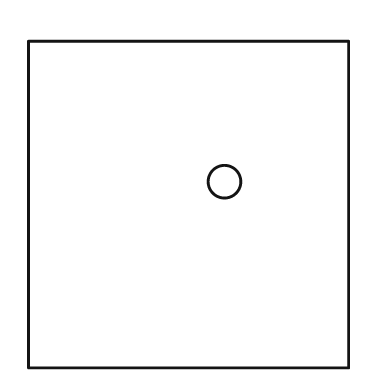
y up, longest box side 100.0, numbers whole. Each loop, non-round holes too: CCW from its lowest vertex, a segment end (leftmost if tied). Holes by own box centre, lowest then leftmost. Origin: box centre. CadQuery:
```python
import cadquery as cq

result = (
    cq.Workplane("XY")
    .moveTo(-49.0, -50.0)
    .lineTo(49.0, -50.0)
    .lineTo(49.0, 50.0)
    .lineTo(-49.0, 50.0)
    .close()
    .moveTo(11.0, 7.0)
    .circle(5.0)
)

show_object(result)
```